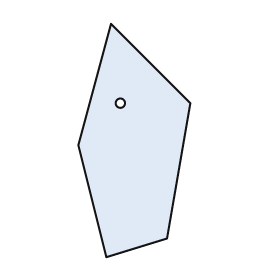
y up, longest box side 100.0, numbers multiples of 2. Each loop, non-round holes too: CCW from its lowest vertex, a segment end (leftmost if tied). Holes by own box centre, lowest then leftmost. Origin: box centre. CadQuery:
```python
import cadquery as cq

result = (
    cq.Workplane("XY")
    .moveTo(-12.0, -50.0)
    .lineTo(14.0, -42.0)
    .lineTo(24.0, 16.0)
    .lineTo(-10.0, 50.0)
    .lineTo(-24.0, -2.0)
    .close()
    .moveTo(-6.0, 16.0)
    .circle(2.0)
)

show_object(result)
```